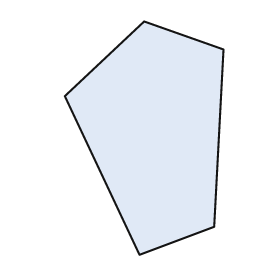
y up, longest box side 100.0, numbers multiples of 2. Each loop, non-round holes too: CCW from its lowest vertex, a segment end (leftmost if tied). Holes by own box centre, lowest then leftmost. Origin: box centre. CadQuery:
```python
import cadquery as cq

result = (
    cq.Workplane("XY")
    .moveTo(-2.0, -50.0)
    .lineTo(30.0, -38.0)
    .lineTo(34.0, 38.0)
    .lineTo(0.0, 50.0)
    .lineTo(-34.0, 18.0)
    .close()
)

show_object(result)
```